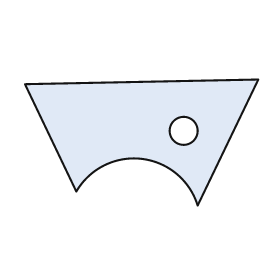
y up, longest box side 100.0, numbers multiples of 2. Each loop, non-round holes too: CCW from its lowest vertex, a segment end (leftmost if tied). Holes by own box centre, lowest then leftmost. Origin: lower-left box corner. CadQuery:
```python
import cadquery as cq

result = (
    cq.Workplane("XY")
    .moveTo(74.0, 0.0)
    .lineTo(100.0, 54.0)
    .lineTo(0.0, 52.0)
    .lineTo(22.0, 6.0)
    .threePointArc((50.0, 20.0), (74.0, 0.0))
    .close()
    .moveTo(68.0, 32.0)
    .circle(6.0)
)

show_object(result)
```